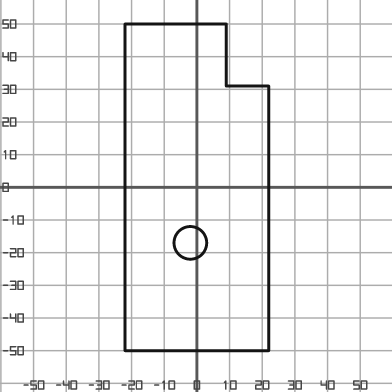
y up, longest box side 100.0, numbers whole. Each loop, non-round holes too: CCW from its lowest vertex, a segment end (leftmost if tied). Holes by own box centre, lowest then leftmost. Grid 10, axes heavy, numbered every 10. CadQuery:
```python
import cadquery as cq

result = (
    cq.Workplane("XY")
    .moveTo(-22.0, -50.0)
    .lineTo(22.0, -50.0)
    .lineTo(22.0, 31.0)
    .lineTo(9.0, 31.0)
    .lineTo(9.0, 50.0)
    .lineTo(-22.0, 50.0)
    .close()
    .moveTo(-2.0, -17.0)
    .circle(5.0)
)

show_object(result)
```